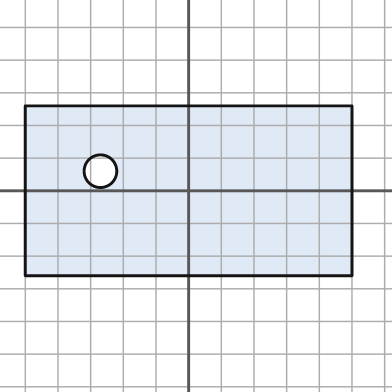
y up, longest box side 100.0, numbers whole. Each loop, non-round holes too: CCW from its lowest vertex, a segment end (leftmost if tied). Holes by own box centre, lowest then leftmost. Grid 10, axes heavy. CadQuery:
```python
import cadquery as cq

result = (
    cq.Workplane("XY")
    .moveTo(-50.0, -26.0)
    .lineTo(50.0, -26.0)
    .lineTo(50.0, 26.0)
    .lineTo(-50.0, 26.0)
    .close()
    .moveTo(-27.0, 6.0)
    .circle(5.0)
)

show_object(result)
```